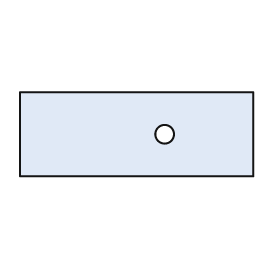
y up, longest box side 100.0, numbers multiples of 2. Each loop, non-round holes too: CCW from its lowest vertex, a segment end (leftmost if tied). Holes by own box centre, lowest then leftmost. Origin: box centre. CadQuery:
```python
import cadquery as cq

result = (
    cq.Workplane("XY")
    .moveTo(-50.0, -18.0)
    .lineTo(50.0, -18.0)
    .lineTo(50.0, 18.0)
    .lineTo(-50.0, 18.0)
    .close()
    .moveTo(12.0, 0.0)
    .circle(4.0)
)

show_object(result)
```